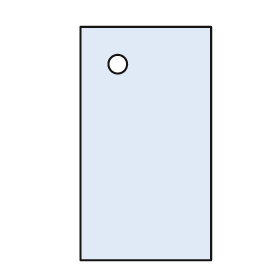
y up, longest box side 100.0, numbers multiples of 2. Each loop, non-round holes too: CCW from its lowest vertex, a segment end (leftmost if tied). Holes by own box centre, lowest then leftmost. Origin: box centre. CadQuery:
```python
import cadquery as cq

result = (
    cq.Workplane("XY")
    .moveTo(-28.0, -50.0)
    .lineTo(28.0, -50.0)
    .lineTo(28.0, 50.0)
    .lineTo(-28.0, 50.0)
    .close()
    .moveTo(-12.0, 34.0)
    .circle(4.0)
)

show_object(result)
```